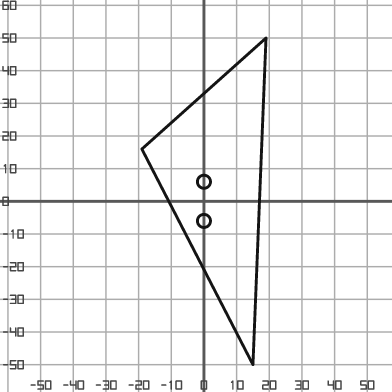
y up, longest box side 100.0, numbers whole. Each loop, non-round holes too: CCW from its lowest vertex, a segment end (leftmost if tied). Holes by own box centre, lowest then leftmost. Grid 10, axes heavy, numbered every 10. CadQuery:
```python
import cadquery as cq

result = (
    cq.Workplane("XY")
    .moveTo(15.0, -50.0)
    .lineTo(19.0, 50.0)
    .lineTo(-19.0, 16.0)
    .close()
    .moveTo(0.0, -6.0)
    .circle(2.0)
    .moveTo(0.0, 6.0)
    .circle(2.0)
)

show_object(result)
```